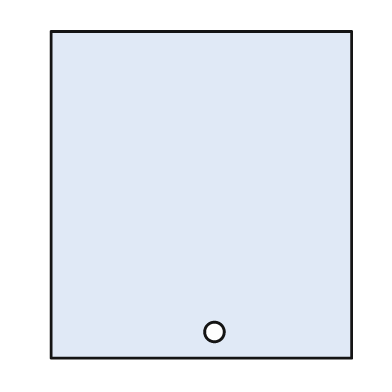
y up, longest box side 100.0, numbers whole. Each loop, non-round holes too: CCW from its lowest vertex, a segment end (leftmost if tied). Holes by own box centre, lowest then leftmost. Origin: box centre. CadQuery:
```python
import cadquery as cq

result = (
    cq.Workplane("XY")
    .moveTo(-46.0, -50.0)
    .lineTo(46.0, -50.0)
    .lineTo(46.0, 50.0)
    .lineTo(-46.0, 50.0)
    .close()
    .moveTo(4.0, -42.0)
    .circle(3.0)
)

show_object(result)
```